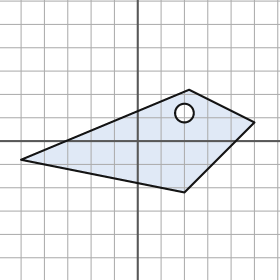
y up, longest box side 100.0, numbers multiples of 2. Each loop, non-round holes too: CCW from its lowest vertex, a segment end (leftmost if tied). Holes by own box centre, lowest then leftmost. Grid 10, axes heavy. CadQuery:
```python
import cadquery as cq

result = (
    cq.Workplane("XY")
    .moveTo(20.0, -22.0)
    .lineTo(50.0, 8.0)
    .lineTo(22.0, 22.0)
    .lineTo(-50.0, -8.0)
    .close()
    .moveTo(20.0, 12.0)
    .circle(4.0)
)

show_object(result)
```